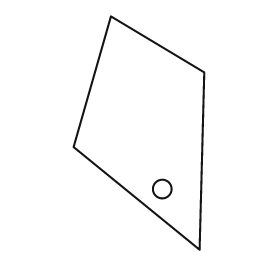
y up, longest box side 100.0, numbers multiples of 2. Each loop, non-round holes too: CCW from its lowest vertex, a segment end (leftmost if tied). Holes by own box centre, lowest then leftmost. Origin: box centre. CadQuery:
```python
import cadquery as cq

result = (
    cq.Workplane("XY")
    .moveTo(26.0, -50.0)
    .lineTo(28.0, 26.0)
    .lineTo(-12.0, 50.0)
    .lineTo(-28.0, -6.0)
    .close()
    .moveTo(10.0, -24.0)
    .circle(4.0)
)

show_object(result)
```